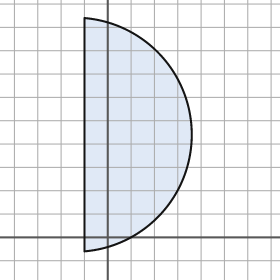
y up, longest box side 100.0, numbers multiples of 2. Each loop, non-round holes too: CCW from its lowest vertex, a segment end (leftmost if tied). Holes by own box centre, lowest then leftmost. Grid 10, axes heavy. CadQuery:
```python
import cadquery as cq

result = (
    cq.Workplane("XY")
    .moveTo(-10.0, -6.0)
    .threePointArc((36.0, 44.0), (-10.0, 94.0))
    .close()
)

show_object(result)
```